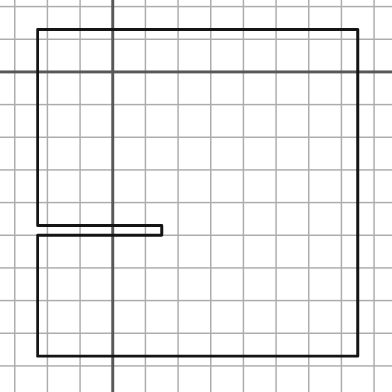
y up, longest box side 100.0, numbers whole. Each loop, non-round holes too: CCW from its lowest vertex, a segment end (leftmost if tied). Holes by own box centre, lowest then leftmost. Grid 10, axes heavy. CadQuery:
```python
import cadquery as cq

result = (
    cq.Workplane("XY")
    .moveTo(-23.0, -87.0)
    .lineTo(75.0, -87.0)
    .lineTo(75.0, 13.0)
    .lineTo(-23.0, 13.0)
    .lineTo(-23.0, -47.0)
    .lineTo(15.0, -47.0)
    .lineTo(15.0, -50.0)
    .lineTo(-23.0, -50.0)
    .close()
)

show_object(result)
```